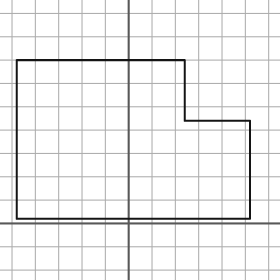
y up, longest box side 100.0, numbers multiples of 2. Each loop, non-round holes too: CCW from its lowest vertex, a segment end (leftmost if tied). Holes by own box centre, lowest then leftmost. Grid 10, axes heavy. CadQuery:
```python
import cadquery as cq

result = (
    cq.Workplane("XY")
    .moveTo(-48.0, 2.0)
    .lineTo(52.0, 2.0)
    .lineTo(52.0, 44.0)
    .lineTo(24.0, 44.0)
    .lineTo(24.0, 70.0)
    .lineTo(-48.0, 70.0)
    .close()
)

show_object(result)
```